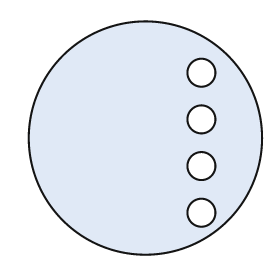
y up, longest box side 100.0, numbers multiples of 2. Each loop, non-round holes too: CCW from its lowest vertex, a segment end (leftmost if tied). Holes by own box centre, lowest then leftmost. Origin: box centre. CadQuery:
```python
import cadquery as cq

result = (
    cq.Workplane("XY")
    .moveTo(0.0, 0.0)
    .circle(50.0)
    .moveTo(24.0, -32.0)
    .circle(6.0)
    .moveTo(24.0, -12.0)
    .circle(6.0)
    .moveTo(24.0, 8.0)
    .circle(6.0)
    .moveTo(24.0, 28.0)
    .circle(6.0)
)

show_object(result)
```